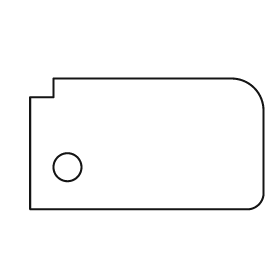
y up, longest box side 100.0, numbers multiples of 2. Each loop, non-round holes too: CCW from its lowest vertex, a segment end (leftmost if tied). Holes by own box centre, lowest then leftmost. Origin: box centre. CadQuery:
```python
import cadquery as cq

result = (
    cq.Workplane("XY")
    .moveTo(-50.0, -28.0)
    .lineTo(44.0, -28.0)
    .threePointArc((48.0, -26.0), (50.0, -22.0))
    .lineTo(50.0, 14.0)
    .threePointArc((46.0, 24.0), (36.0, 28.0))
    .lineTo(-40.0, 28.0)
    .lineTo(-40.0, 20.0)
    .lineTo(-50.0, 20.0)
    .close()
    .moveTo(-34.0, -10.0)
    .circle(6.0)
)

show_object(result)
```